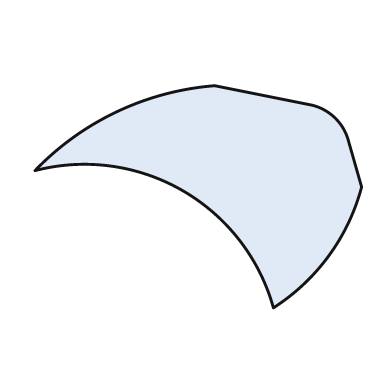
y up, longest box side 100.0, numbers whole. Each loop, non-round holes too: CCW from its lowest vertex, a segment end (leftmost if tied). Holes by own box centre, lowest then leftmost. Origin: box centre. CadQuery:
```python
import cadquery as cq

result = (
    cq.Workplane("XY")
    .moveTo(23.0, -34.0)
    .threePointArc((40.0, -18.0), (50.0, 3.0))
    .lineTo(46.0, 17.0)
    .threePointArc((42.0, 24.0), (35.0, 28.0))
    .lineTo(5.0, 34.0)
    .threePointArc((-25.0, 26.0), (-50.0, 8.0))
    .threePointArc((-5.0, 2.0), (23.0, -34.0))
    .close()
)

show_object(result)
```